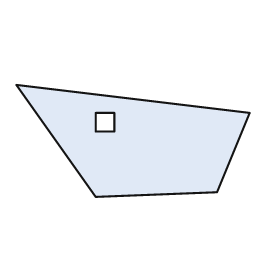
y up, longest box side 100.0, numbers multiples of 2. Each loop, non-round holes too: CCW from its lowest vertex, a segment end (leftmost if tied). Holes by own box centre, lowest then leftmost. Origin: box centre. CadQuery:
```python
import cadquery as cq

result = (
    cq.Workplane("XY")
    .moveTo(-16.0, -24.0)
    .lineTo(36.0, -22.0)
    .lineTo(50.0, 12.0)
    .lineTo(-50.0, 24.0)
    .close()
    .moveTo(-16.0, 4.0)
    .lineTo(-8.0, 4.0)
    .lineTo(-8.0, 12.0)
    .lineTo(-16.0, 12.0)
    .close()
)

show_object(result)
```